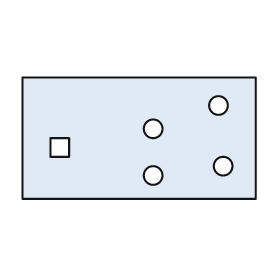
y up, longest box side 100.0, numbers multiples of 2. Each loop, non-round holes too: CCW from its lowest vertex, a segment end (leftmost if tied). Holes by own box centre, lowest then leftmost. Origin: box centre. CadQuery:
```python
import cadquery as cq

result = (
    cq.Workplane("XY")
    .moveTo(-50.0, -26.0)
    .lineTo(50.0, -26.0)
    .lineTo(50.0, 26.0)
    .lineTo(-50.0, 26.0)
    .close()
    .moveTo(6.0, -16.0)
    .circle(4.0)
    .moveTo(36.0, -12.0)
    .circle(4.0)
    .moveTo(-38.0, -8.0)
    .lineTo(-30.0, -8.0)
    .lineTo(-30.0, 0.0)
    .lineTo(-38.0, 0.0)
    .close()
    .moveTo(6.0, 4.0)
    .circle(4.0)
    .moveTo(34.0, 14.0)
    .circle(4.0)
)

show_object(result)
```